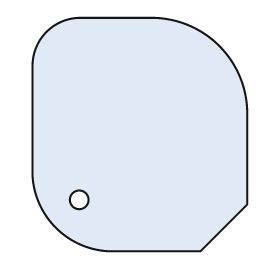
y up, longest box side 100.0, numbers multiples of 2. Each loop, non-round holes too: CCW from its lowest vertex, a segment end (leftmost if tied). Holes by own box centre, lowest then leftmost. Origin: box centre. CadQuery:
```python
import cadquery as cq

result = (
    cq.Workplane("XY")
    .moveTo(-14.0, -50.0)
    .lineTo(26.0, -50.0)
    .lineTo(46.0, -30.0)
    .lineTo(46.0, 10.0)
    .threePointArc((34.0, 38.0), (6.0, 50.0))
    .lineTo(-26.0, 50.0)
    .threePointArc((-40.0, 44.0), (-46.0, 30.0))
    .lineTo(-46.0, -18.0)
    .threePointArc((-36.0, -40.0), (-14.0, -50.0))
    .close()
    .moveTo(-26.0, -28.0)
    .circle(4.0)
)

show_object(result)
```